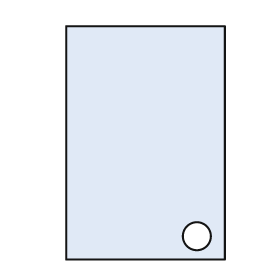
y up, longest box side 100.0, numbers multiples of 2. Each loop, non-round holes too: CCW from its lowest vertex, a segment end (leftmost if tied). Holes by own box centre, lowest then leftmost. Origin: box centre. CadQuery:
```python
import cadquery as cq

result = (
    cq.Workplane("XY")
    .moveTo(-34.0, -50.0)
    .lineTo(34.0, -50.0)
    .lineTo(34.0, 50.0)
    .lineTo(-34.0, 50.0)
    .close()
    .moveTo(22.0, -40.0)
    .circle(6.0)
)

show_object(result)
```